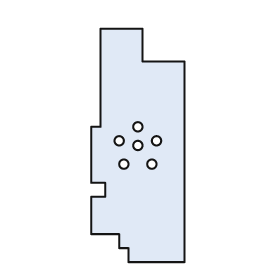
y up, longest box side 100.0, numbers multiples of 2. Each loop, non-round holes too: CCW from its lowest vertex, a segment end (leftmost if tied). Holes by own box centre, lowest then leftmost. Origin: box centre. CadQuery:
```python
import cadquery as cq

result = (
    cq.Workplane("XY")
    .moveTo(-4.0, -50.0)
    .lineTo(20.0, -50.0)
    .lineTo(20.0, 36.0)
    .lineTo(2.0, 36.0)
    .lineTo(2.0, 50.0)
    .lineTo(-16.0, 50.0)
    .lineTo(-16.0, 8.0)
    .lineTo(-20.0, 8.0)
    .lineTo(-20.0, -16.0)
    .lineTo(-14.0, -16.0)
    .lineTo(-14.0, -22.0)
    .lineTo(-20.0, -22.0)
    .lineTo(-20.0, -38.0)
    .lineTo(-8.0, -38.0)
    .lineTo(-8.0, -44.0)
    .lineTo(-4.0, -44.0)
    .close()
    .moveTo(-6.0, -8.0)
    .circle(2.0)
    .moveTo(6.0, -8.0)
    .circle(2.0)
    .moveTo(0.0, 0.0)
    .circle(2.0)
    .moveTo(-8.0, 2.0)
    .circle(2.0)
    .moveTo(8.0, 2.0)
    .circle(2.0)
    .moveTo(0.0, 8.0)
    .circle(2.0)
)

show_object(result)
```